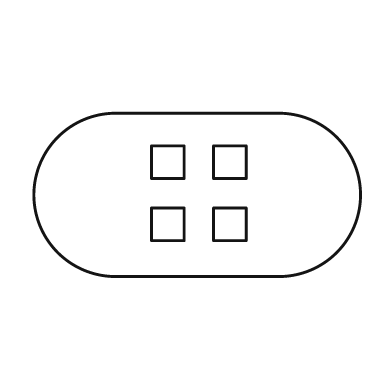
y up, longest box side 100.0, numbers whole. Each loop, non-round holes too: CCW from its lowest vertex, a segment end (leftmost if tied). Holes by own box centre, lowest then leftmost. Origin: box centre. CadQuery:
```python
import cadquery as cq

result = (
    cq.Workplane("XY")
    .moveTo(-25.0, -25.0)
    .lineTo(25.0, -25.0)
    .threePointArc((50.0, 0.0), (25.0, 25.0))
    .lineTo(-25.0, 25.0)
    .threePointArc((-50.0, 0.0), (-25.0, -25.0))
    .close()
    .moveTo(-14.0, -14.0)
    .lineTo(-4.0, -14.0)
    .lineTo(-4.0, -4.0)
    .lineTo(-14.0, -4.0)
    .close()
    .moveTo(5.0, -14.0)
    .lineTo(15.0, -14.0)
    .lineTo(15.0, -4.0)
    .lineTo(5.0, -4.0)
    .close()
    .moveTo(-14.0, 5.0)
    .lineTo(-4.0, 5.0)
    .lineTo(-4.0, 15.0)
    .lineTo(-14.0, 15.0)
    .close()
    .moveTo(5.0, 5.0)
    .lineTo(15.0, 5.0)
    .lineTo(15.0, 15.0)
    .lineTo(5.0, 15.0)
    .close()
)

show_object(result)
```